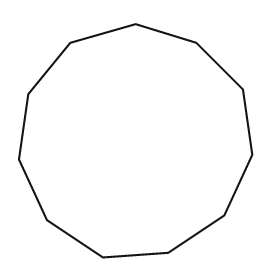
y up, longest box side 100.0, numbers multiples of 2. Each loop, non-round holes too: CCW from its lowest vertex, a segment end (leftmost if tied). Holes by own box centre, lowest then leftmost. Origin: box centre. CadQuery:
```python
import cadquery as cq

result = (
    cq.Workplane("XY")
    .moveTo(-14.0, -50.0)
    .lineTo(14.0, -48.0)
    .lineTo(38.0, -32.0)
    .lineTo(50.0, -6.0)
    .lineTo(46.0, 22.0)
    .lineTo(26.0, 42.0)
    .lineTo(0.0, 50.0)
    .lineTo(-28.0, 42.0)
    .lineTo(-46.0, 20.0)
    .lineTo(-50.0, -8.0)
    .lineTo(-38.0, -34.0)
    .close()
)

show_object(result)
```